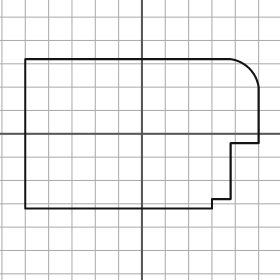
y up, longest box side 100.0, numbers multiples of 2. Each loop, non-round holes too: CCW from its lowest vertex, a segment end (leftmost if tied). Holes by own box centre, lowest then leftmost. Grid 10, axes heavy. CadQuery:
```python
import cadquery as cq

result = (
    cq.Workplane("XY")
    .moveTo(-50.0, -32.0)
    .lineTo(30.0, -32.0)
    .lineTo(30.0, -28.0)
    .lineTo(38.0, -28.0)
    .lineTo(38.0, -4.0)
    .lineTo(50.0, -4.0)
    .lineTo(50.0, 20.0)
    .threePointArc((46.0, 28.0), (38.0, 32.0))
    .lineTo(-50.0, 32.0)
    .close()
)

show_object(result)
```